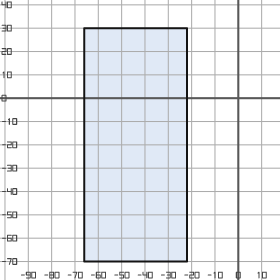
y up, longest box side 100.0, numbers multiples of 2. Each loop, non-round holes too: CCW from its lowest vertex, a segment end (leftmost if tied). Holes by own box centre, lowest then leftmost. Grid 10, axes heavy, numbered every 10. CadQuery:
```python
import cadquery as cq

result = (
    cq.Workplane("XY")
    .moveTo(-66.0, -70.0)
    .lineTo(-22.0, -70.0)
    .lineTo(-22.0, 30.0)
    .lineTo(-66.0, 30.0)
    .close()
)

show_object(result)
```